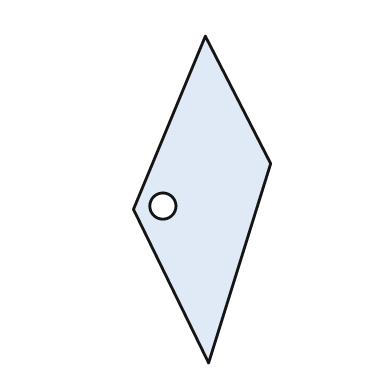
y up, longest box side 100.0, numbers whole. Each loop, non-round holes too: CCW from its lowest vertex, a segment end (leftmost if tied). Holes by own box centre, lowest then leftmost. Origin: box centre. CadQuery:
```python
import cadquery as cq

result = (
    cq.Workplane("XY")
    .moveTo(2.0, -50.0)
    .lineTo(21.0, 11.0)
    .lineTo(1.0, 50.0)
    .lineTo(-21.0, -3.0)
    .close()
    .moveTo(-12.0, -2.0)
    .circle(4.0)
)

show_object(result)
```